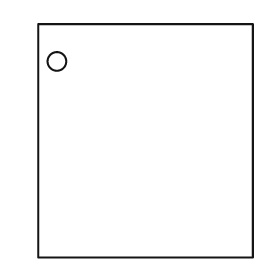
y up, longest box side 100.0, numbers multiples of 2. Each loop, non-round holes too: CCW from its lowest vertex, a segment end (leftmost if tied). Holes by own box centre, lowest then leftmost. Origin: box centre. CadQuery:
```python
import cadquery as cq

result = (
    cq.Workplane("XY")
    .moveTo(-46.0, -50.0)
    .lineTo(46.0, -50.0)
    .lineTo(46.0, 50.0)
    .lineTo(-46.0, 50.0)
    .close()
    .moveTo(-38.0, 34.0)
    .circle(4.0)
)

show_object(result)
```